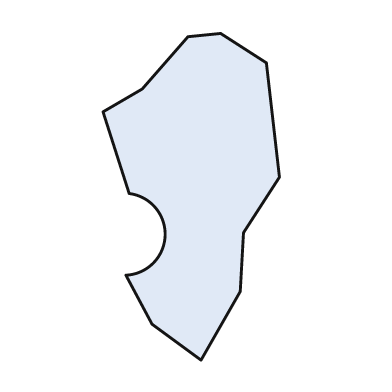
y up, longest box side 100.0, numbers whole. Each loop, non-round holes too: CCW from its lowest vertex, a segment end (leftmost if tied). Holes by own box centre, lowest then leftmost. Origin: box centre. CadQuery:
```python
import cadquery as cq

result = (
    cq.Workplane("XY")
    .moveTo(3.0, -50.0)
    .lineTo(15.0, -29.0)
    .lineTo(16.0, -11.0)
    .lineTo(27.0, 6.0)
    .lineTo(23.0, 41.0)
    .lineTo(9.0, 50.0)
    .lineTo(-1.0, 49.0)
    .lineTo(-15.0, 33.0)
    .lineTo(-27.0, 26.0)
    .lineTo(-19.0, 1.0)
    .threePointArc((-8.0, -12.0), (-20.0, -24.0))
    .lineTo(-12.0, -39.0)
    .close()
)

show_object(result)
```